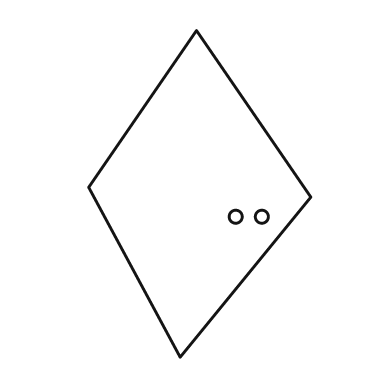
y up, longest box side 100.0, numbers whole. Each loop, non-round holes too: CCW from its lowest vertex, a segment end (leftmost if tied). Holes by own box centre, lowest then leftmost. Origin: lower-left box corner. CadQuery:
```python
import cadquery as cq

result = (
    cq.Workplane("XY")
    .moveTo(28.0, 0.0)
    .lineTo(68.0, 49.0)
    .lineTo(33.0, 100.0)
    .lineTo(0.0, 52.0)
    .close()
    .moveTo(45.0, 43.0)
    .circle(2.0)
    .moveTo(53.0, 43.0)
    .circle(2.0)
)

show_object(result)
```